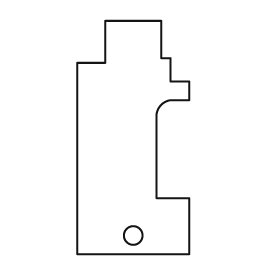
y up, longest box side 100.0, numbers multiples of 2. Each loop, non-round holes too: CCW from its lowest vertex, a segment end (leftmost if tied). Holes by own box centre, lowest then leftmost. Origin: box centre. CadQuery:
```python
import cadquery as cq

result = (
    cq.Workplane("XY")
    .moveTo(-24.0, -50.0)
    .lineTo(24.0, -50.0)
    .lineTo(24.0, -26.0)
    .lineTo(10.0, -26.0)
    .lineTo(10.0, 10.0)
    .threePointArc((12.0, 14.0), (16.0, 16.0))
    .lineTo(24.0, 16.0)
    .lineTo(24.0, 24.0)
    .lineTo(16.0, 24.0)
    .lineTo(16.0, 34.0)
    .lineTo(12.0, 34.0)
    .lineTo(12.0, 50.0)
    .lineTo(-12.0, 50.0)
    .lineTo(-12.0, 32.0)
    .lineTo(-24.0, 32.0)
    .close()
    .moveTo(0.0, -42.0)
    .circle(4.0)
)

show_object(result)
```